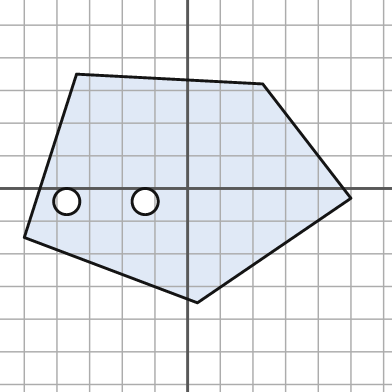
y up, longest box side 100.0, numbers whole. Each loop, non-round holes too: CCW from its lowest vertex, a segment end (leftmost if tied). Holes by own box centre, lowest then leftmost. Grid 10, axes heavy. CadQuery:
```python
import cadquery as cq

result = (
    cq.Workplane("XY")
    .moveTo(3.0, -35.0)
    .lineTo(50.0, -3.0)
    .lineTo(23.0, 32.0)
    .lineTo(-34.0, 35.0)
    .lineTo(-50.0, -15.0)
    .close()
    .moveTo(-37.0, -4.0)
    .circle(4.0)
    .moveTo(-13.0, -4.0)
    .circle(4.0)
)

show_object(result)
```